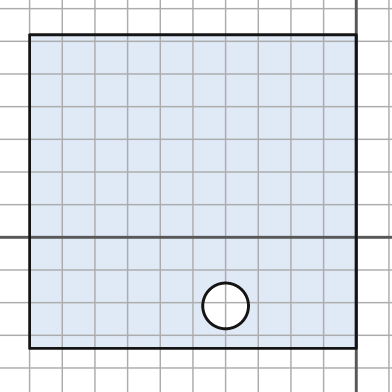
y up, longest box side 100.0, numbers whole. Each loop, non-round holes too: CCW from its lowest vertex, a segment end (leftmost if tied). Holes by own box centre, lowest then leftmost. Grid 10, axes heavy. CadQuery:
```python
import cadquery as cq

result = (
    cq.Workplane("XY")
    .moveTo(-100.0, -34.0)
    .lineTo(0.0, -34.0)
    .lineTo(0.0, 62.0)
    .lineTo(-100.0, 62.0)
    .close()
    .moveTo(-40.0, -21.0)
    .circle(7.0)
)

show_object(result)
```